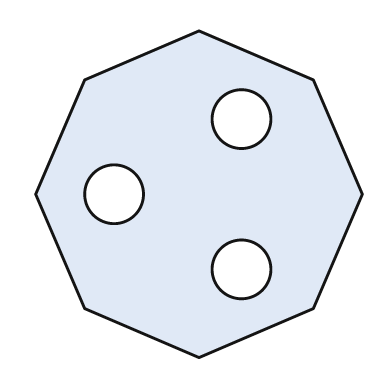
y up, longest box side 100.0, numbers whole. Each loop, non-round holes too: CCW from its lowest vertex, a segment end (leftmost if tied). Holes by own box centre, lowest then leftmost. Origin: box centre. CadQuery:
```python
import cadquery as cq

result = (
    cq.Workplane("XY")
    .moveTo(0.0, -50.0)
    .lineTo(35.0, -35.0)
    .lineTo(50.0, 0.0)
    .lineTo(35.0, 35.0)
    .lineTo(0.0, 50.0)
    .lineTo(-35.0, 35.0)
    .lineTo(-50.0, 0.0)
    .lineTo(-35.0, -35.0)
    .close()
    .moveTo(13.0, -23.0)
    .circle(9.0)
    .moveTo(-26.0, 0.0)
    .circle(9.0)
    .moveTo(13.0, 23.0)
    .circle(9.0)
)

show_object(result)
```